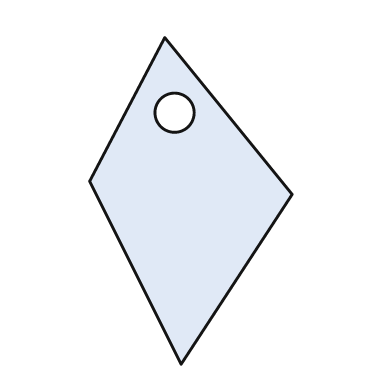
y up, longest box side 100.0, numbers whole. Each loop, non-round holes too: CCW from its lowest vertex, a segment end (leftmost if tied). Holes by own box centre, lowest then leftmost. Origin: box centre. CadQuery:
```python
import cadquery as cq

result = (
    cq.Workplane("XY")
    .moveTo(-3.0, -50.0)
    .lineTo(31.0, 2.0)
    .lineTo(-8.0, 50.0)
    .lineTo(-31.0, 6.0)
    .close()
    .moveTo(-5.0, 27.0)
    .circle(6.0)
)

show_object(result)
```